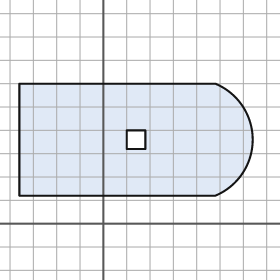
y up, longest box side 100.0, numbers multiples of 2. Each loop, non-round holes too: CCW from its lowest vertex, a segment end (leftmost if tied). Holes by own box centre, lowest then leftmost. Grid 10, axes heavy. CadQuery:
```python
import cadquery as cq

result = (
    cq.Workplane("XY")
    .moveTo(-36.0, 12.0)
    .lineTo(48.0, 12.0)
    .threePointArc((64.0, 36.0), (48.0, 60.0))
    .lineTo(-36.0, 60.0)
    .close()
    .moveTo(10.0, 32.0)
    .lineTo(18.0, 32.0)
    .lineTo(18.0, 40.0)
    .lineTo(10.0, 40.0)
    .close()
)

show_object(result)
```